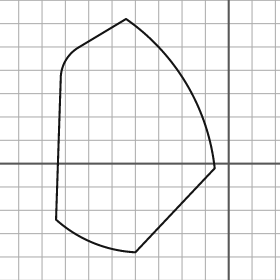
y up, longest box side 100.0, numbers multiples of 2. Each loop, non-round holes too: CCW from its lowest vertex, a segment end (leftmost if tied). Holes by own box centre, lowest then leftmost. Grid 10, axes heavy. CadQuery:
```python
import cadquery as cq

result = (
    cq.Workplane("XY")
    .moveTo(-40.0, -38.0)
    .lineTo(-6.0, -2.0)
    .threePointArc((-18.0, 34.0), (-44.0, 62.0))
    .lineTo(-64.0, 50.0)
    .threePointArc((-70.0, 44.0), (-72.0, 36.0))
    .lineTo(-74.0, -24.0)
    .threePointArc((-58.0, -34.0), (-40.0, -38.0))
    .close()
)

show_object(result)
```